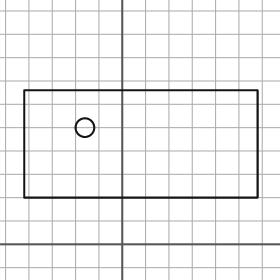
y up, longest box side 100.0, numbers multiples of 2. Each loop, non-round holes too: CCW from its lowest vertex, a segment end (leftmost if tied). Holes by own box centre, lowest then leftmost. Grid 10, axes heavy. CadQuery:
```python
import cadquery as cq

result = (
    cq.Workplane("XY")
    .moveTo(-42.0, 20.0)
    .lineTo(58.0, 20.0)
    .lineTo(58.0, 66.0)
    .lineTo(-42.0, 66.0)
    .close()
    .moveTo(-16.0, 50.0)
    .circle(4.0)
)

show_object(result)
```